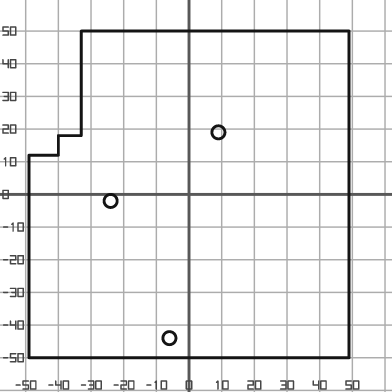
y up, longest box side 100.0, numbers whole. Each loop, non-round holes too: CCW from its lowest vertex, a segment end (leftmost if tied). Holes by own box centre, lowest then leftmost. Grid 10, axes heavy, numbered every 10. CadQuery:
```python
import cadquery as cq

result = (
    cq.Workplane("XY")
    .moveTo(-49.0, -50.0)
    .lineTo(49.0, -50.0)
    .lineTo(49.0, 50.0)
    .lineTo(-33.0, 50.0)
    .lineTo(-33.0, 18.0)
    .lineTo(-40.0, 18.0)
    .lineTo(-40.0, 12.0)
    .lineTo(-49.0, 12.0)
    .close()
    .moveTo(-6.0, -44.0)
    .circle(2.0)
    .moveTo(-24.0, -2.0)
    .circle(2.0)
    .moveTo(9.0, 19.0)
    .circle(2.0)
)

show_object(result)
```